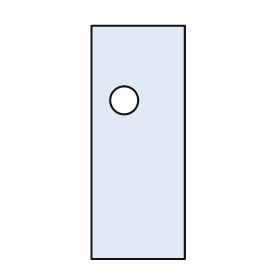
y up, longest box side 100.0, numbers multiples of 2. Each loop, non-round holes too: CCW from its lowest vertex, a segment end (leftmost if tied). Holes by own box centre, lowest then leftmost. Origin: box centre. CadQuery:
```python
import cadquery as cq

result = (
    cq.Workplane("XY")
    .moveTo(-20.0, -50.0)
    .lineTo(20.0, -50.0)
    .lineTo(20.0, 50.0)
    .lineTo(-20.0, 50.0)
    .close()
    .moveTo(-6.0, 18.0)
    .circle(6.0)
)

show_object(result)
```